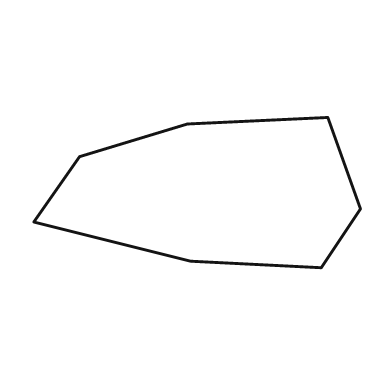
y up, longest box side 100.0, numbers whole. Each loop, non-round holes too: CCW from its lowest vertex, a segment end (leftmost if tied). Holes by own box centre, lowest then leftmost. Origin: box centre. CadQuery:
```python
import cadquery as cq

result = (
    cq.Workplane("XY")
    .moveTo(38.0, -23.0)
    .lineTo(50.0, -5.0)
    .lineTo(40.0, 23.0)
    .lineTo(-3.0, 21.0)
    .lineTo(-36.0, 11.0)
    .lineTo(-50.0, -9.0)
    .lineTo(-2.0, -21.0)
    .close()
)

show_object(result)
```